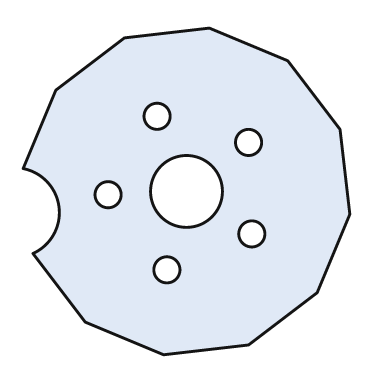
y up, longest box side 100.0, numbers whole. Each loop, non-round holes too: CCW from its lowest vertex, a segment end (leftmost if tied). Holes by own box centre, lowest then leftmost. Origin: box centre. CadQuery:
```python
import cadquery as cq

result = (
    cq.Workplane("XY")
    .moveTo(-7.0, -50.0)
    .lineTo(19.0, -47.0)
    .lineTo(40.0, -31.0)
    .lineTo(50.0, -7.0)
    .lineTo(47.0, 19.0)
    .lineTo(31.0, 40.0)
    .lineTo(7.0, 50.0)
    .lineTo(-19.0, 47.0)
    .lineTo(-40.0, 31.0)
    .lineTo(-50.0, 7.0)
    .threePointArc((-39.0, -5.0), (-47.0, -19.0))
    .lineTo(-31.0, -40.0)
    .close()
    .moveTo(-6.0, -24.0)
    .circle(4.0)
    .moveTo(20.0, -13.0)
    .circle(4.0)
    .moveTo(-24.0, -1.0)
    .circle(4.0)
    .moveTo(0.0, 0.0)
    .circle(11.0)
    .moveTo(19.0, 15.0)
    .circle(4.0)
    .moveTo(-9.0, 23.0)
    .circle(4.0)
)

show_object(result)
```